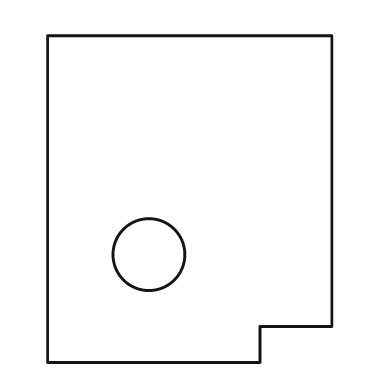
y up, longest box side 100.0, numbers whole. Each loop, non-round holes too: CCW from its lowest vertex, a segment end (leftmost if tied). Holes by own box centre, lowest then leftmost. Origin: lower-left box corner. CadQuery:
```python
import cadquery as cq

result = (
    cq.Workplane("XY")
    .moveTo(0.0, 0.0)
    .lineTo(65.0, 0.0)
    .lineTo(65.0, 11.0)
    .lineTo(87.0, 11.0)
    .lineTo(87.0, 100.0)
    .lineTo(0.0, 100.0)
    .close()
    .moveTo(31.0, 33.0)
    .circle(11.0)
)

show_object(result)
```